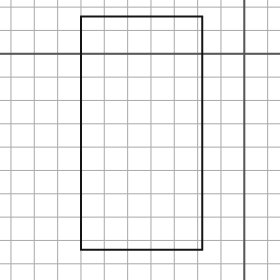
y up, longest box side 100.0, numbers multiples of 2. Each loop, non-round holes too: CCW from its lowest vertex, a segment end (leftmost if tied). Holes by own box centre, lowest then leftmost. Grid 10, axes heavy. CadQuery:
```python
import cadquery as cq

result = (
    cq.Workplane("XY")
    .moveTo(-70.0, -84.0)
    .lineTo(-18.0, -84.0)
    .lineTo(-18.0, 16.0)
    .lineTo(-70.0, 16.0)
    .close()
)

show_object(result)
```